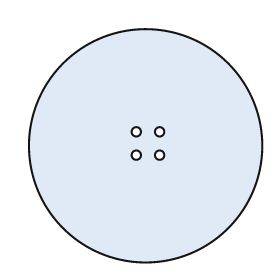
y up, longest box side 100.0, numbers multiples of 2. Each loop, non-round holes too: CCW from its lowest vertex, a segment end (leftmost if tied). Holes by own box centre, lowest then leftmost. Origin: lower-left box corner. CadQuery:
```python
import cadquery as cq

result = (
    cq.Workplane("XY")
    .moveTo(50.0, 50.0)
    .circle(50.0)
    .moveTo(46.0, 46.0)
    .circle(2.0)
    .moveTo(56.0, 46.0)
    .circle(2.0)
    .moveTo(46.0, 56.0)
    .circle(2.0)
    .moveTo(56.0, 56.0)
    .circle(2.0)
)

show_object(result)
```